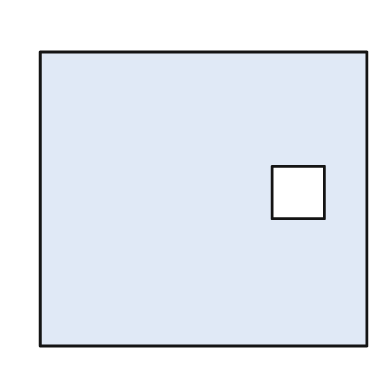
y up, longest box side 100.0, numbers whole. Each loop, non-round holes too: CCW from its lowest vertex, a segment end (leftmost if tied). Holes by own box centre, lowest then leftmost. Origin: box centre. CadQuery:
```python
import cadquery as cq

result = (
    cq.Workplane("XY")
    .moveTo(-50.0, -45.0)
    .lineTo(50.0, -45.0)
    .lineTo(50.0, 45.0)
    .lineTo(-50.0, 45.0)
    .close()
    .moveTo(21.0, -6.0)
    .lineTo(37.0, -6.0)
    .lineTo(37.0, 10.0)
    .lineTo(21.0, 10.0)
    .close()
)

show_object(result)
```